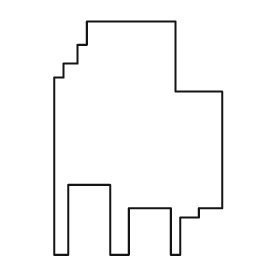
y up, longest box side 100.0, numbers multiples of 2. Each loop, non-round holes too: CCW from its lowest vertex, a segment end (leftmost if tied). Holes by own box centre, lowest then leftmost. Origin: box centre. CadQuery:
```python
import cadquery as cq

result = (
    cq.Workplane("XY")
    .moveTo(-36.0, -50.0)
    .lineTo(-30.0, -50.0)
    .lineTo(-30.0, -20.0)
    .lineTo(-12.0, -20.0)
    .lineTo(-12.0, -50.0)
    .lineTo(-4.0, -50.0)
    .lineTo(-4.0, -30.0)
    .lineTo(14.0, -30.0)
    .lineTo(14.0, -50.0)
    .lineTo(18.0, -50.0)
    .lineTo(18.0, -34.0)
    .lineTo(26.0, -34.0)
    .lineTo(26.0, -30.0)
    .lineTo(36.0, -30.0)
    .lineTo(36.0, 20.0)
    .lineTo(16.0, 20.0)
    .lineTo(16.0, 50.0)
    .lineTo(-22.0, 50.0)
    .lineTo(-22.0, 40.0)
    .lineTo(-26.0, 40.0)
    .lineTo(-26.0, 32.0)
    .lineTo(-32.0, 32.0)
    .lineTo(-32.0, 26.0)
    .lineTo(-36.0, 26.0)
    .close()
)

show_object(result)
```